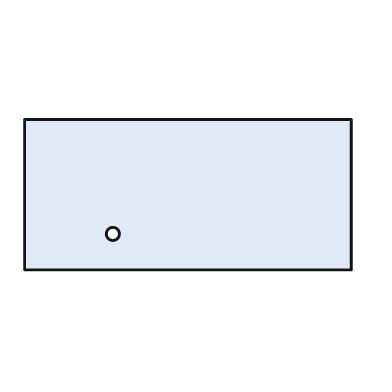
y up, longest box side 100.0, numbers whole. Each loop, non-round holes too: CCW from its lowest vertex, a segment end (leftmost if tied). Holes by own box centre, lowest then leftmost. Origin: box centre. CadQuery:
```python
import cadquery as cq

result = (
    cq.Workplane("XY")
    .moveTo(-50.0, -23.0)
    .lineTo(50.0, -23.0)
    .lineTo(50.0, 23.0)
    .lineTo(-50.0, 23.0)
    .close()
    .moveTo(-23.0, -12.0)
    .circle(2.0)
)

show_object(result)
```